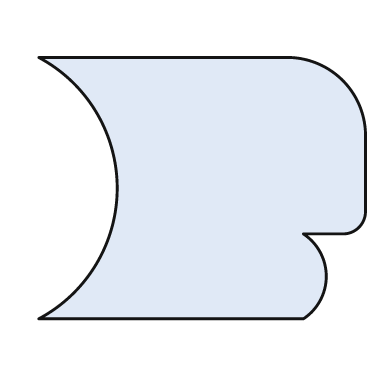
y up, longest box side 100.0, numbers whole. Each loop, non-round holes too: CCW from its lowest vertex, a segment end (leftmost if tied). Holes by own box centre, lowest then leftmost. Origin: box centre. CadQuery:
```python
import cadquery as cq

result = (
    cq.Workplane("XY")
    .moveTo(-50.0, -40.0)
    .lineTo(31.0, -40.0)
    .threePointArc((38.0, -27.0), (31.0, -14.0))
    .lineTo(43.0, -14.0)
    .threePointArc((48.0, -12.0), (50.0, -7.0))
    .lineTo(50.0, 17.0)
    .threePointArc((43.0, 33.0), (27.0, 40.0))
    .lineTo(-50.0, 40.0)
    .threePointArc((-26.0, 0.0), (-50.0, -40.0))
    .close()
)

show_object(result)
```